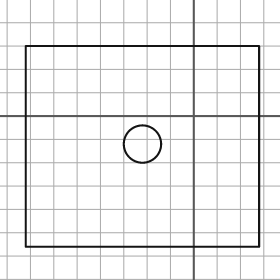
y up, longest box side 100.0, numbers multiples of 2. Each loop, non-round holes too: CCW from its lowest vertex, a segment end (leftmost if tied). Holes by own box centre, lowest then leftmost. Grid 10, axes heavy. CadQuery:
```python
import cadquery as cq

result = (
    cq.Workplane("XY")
    .moveTo(-72.0, -56.0)
    .lineTo(28.0, -56.0)
    .lineTo(28.0, 30.0)
    .lineTo(-72.0, 30.0)
    .close()
    .moveTo(-22.0, -12.0)
    .circle(8.0)
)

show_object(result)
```